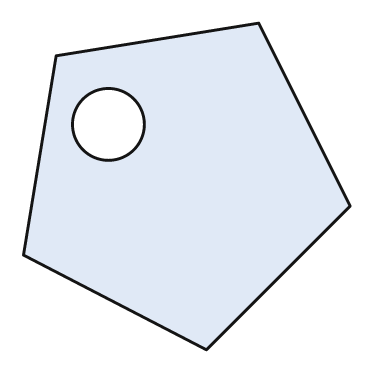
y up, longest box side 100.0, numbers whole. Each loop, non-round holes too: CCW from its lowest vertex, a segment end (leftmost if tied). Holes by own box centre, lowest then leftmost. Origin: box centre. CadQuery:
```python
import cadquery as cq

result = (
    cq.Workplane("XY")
    .moveTo(6.0, -50.0)
    .lineTo(50.0, -6.0)
    .lineTo(22.0, 50.0)
    .lineTo(-40.0, 40.0)
    .lineTo(-50.0, -21.0)
    .close()
    .moveTo(-24.0, 19.0)
    .circle(11.0)
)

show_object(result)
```